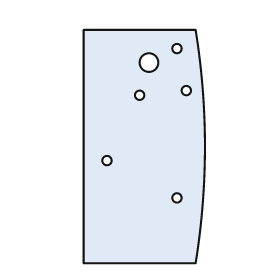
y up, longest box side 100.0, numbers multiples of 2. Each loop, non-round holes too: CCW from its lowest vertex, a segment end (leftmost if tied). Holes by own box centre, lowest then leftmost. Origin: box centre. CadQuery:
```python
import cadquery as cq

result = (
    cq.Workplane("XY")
    .moveTo(-26.0, -50.0)
    .lineTo(22.0, -50.0)
    .threePointArc((26.0, 0.0), (22.0, 50.0))
    .lineTo(-26.0, 50.0)
    .close()
    .moveTo(14.0, -22.0)
    .circle(2.0)
    .moveTo(-16.0, -6.0)
    .circle(2.0)
    .moveTo(-2.0, 22.0)
    .circle(2.0)
    .moveTo(18.0, 24.0)
    .circle(2.0)
    .moveTo(2.0, 36.0)
    .circle(4.0)
    .moveTo(14.0, 42.0)
    .circle(2.0)
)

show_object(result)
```